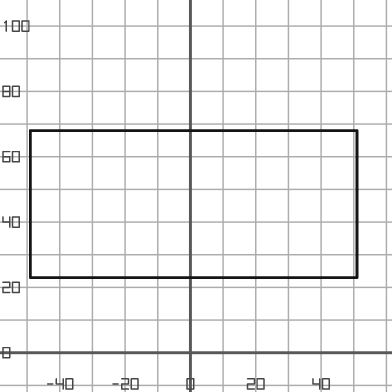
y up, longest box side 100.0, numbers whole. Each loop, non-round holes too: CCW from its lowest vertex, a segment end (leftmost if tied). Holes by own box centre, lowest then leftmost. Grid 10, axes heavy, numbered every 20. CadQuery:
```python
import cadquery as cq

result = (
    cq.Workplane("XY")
    .moveTo(-49.0, 23.0)
    .lineTo(51.0, 23.0)
    .lineTo(51.0, 68.0)
    .lineTo(-49.0, 68.0)
    .close()
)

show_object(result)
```